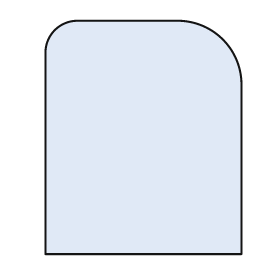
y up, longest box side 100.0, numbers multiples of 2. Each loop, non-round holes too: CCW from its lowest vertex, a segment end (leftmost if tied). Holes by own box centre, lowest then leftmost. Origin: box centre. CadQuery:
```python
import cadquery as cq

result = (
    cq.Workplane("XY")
    .moveTo(-42.0, -50.0)
    .lineTo(42.0, -50.0)
    .lineTo(42.0, 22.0)
    .threePointArc((34.0, 42.0), (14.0, 50.0))
    .lineTo(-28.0, 50.0)
    .threePointArc((-38.0, 46.0), (-42.0, 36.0))
    .close()
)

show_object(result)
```